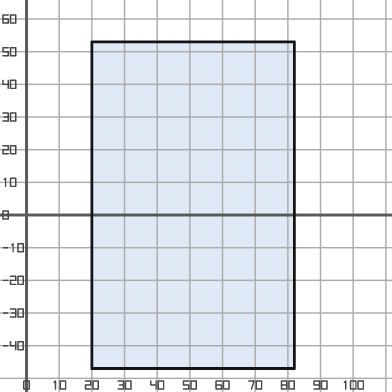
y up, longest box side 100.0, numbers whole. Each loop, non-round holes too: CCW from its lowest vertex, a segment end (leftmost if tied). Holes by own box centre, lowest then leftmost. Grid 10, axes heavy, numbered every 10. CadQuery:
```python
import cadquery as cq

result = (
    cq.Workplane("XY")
    .moveTo(20.0, -47.0)
    .lineTo(82.0, -47.0)
    .lineTo(82.0, 53.0)
    .lineTo(20.0, 53.0)
    .close()
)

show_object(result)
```